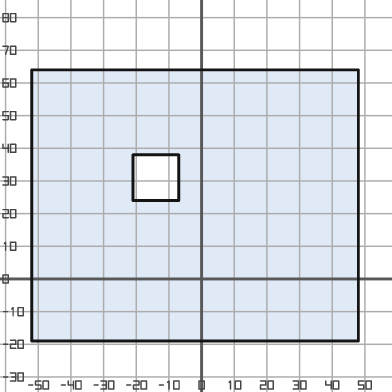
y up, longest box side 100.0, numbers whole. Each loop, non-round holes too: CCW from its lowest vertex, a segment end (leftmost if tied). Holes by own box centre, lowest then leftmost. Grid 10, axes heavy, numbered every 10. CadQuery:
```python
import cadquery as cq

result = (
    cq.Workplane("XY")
    .moveTo(-52.0, -19.0)
    .lineTo(48.0, -19.0)
    .lineTo(48.0, 64.0)
    .lineTo(-52.0, 64.0)
    .close()
    .moveTo(-21.0, 24.0)
    .lineTo(-7.0, 24.0)
    .lineTo(-7.0, 38.0)
    .lineTo(-21.0, 38.0)
    .close()
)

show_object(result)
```